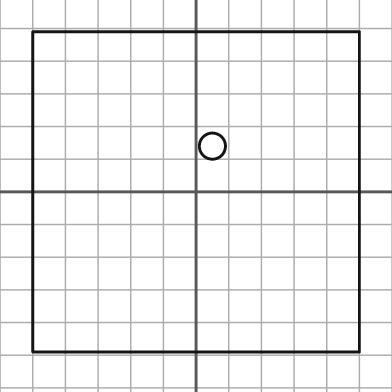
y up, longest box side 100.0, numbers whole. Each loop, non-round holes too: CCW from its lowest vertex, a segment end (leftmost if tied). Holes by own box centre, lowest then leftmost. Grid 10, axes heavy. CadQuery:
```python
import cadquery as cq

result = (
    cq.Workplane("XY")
    .moveTo(-50.0, -49.0)
    .lineTo(50.0, -49.0)
    .lineTo(50.0, 49.0)
    .lineTo(-50.0, 49.0)
    .close()
    .moveTo(5.0, 14.0)
    .circle(4.0)
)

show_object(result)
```